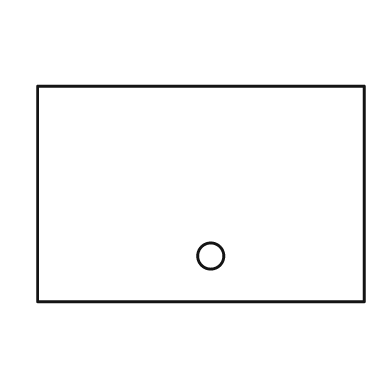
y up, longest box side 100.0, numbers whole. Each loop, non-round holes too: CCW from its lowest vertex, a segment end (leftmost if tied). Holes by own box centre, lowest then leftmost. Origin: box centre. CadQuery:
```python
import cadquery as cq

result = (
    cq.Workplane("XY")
    .moveTo(-50.0, -33.0)
    .lineTo(50.0, -33.0)
    .lineTo(50.0, 33.0)
    .lineTo(-50.0, 33.0)
    .close()
    .moveTo(3.0, -19.0)
    .circle(4.0)
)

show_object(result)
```